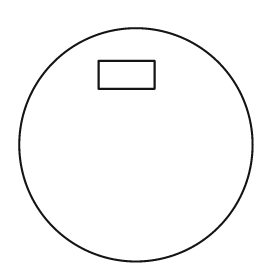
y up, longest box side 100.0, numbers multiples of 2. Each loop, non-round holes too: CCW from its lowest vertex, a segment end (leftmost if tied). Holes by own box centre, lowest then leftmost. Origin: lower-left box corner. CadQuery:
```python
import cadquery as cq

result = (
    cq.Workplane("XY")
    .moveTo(50.0, 50.0)
    .circle(50.0)
    .moveTo(34.0, 74.0)
    .lineTo(58.0, 74.0)
    .lineTo(58.0, 86.0)
    .lineTo(34.0, 86.0)
    .close()
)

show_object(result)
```